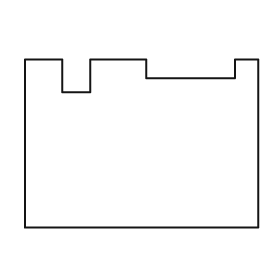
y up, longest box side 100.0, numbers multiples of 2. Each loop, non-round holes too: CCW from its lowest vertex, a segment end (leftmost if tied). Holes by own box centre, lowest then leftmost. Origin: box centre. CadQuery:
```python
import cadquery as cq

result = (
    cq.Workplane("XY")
    .moveTo(-50.0, -36.0)
    .lineTo(50.0, -36.0)
    .lineTo(50.0, 36.0)
    .lineTo(40.0, 36.0)
    .lineTo(40.0, 28.0)
    .lineTo(2.0, 28.0)
    .lineTo(2.0, 36.0)
    .lineTo(-22.0, 36.0)
    .lineTo(-22.0, 22.0)
    .lineTo(-34.0, 22.0)
    .lineTo(-34.0, 36.0)
    .lineTo(-50.0, 36.0)
    .close()
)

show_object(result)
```